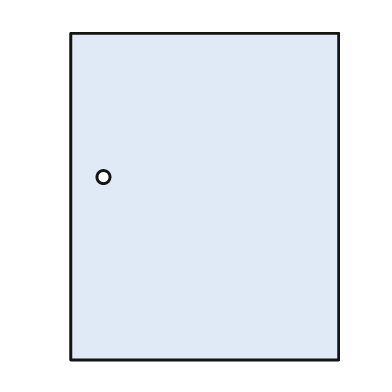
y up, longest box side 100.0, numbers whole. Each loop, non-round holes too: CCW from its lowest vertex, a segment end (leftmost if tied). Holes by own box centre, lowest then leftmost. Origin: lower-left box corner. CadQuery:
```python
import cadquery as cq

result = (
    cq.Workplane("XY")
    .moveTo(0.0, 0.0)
    .lineTo(82.0, 0.0)
    .lineTo(82.0, 100.0)
    .lineTo(0.0, 100.0)
    .close()
    .moveTo(10.0, 56.0)
    .circle(2.0)
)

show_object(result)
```